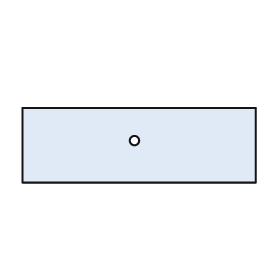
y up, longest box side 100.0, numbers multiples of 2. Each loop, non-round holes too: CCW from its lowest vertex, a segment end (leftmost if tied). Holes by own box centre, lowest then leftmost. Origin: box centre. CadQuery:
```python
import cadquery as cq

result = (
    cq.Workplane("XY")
    .moveTo(-50.0, -16.0)
    .lineTo(50.0, -16.0)
    .lineTo(50.0, 16.0)
    .lineTo(-50.0, 16.0)
    .close()
    .moveTo(-2.0, 2.0)
    .circle(2.0)
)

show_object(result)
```